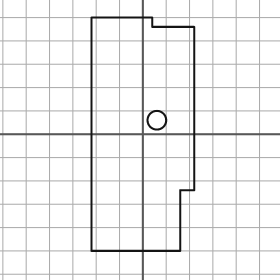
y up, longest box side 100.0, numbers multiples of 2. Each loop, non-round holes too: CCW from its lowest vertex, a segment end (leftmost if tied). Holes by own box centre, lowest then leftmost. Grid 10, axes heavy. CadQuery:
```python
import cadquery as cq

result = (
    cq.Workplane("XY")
    .moveTo(-22.0, -50.0)
    .lineTo(16.0, -50.0)
    .lineTo(16.0, -24.0)
    .lineTo(22.0, -24.0)
    .lineTo(22.0, 46.0)
    .lineTo(4.0, 46.0)
    .lineTo(4.0, 50.0)
    .lineTo(-22.0, 50.0)
    .close()
    .moveTo(6.0, 6.0)
    .circle(4.0)
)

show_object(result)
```